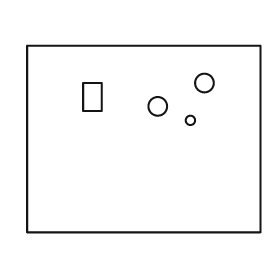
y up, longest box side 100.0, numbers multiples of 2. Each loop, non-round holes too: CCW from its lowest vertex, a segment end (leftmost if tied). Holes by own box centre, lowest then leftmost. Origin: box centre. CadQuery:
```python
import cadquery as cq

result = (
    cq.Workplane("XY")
    .moveTo(-50.0, -40.0)
    .lineTo(50.0, -40.0)
    .lineTo(50.0, 40.0)
    .lineTo(-50.0, 40.0)
    .close()
    .moveTo(20.0, 8.0)
    .circle(2.0)
    .moveTo(6.0, 14.0)
    .circle(4.0)
    .moveTo(-26.0, 12.0)
    .lineTo(-18.0, 12.0)
    .lineTo(-18.0, 24.0)
    .lineTo(-26.0, 24.0)
    .close()
    .moveTo(26.0, 24.0)
    .circle(4.0)
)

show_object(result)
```